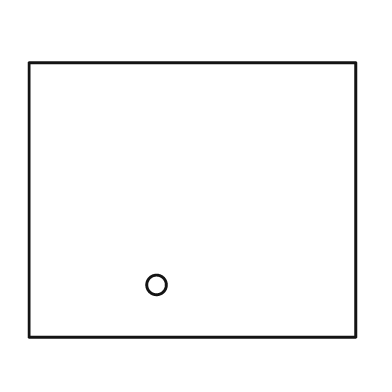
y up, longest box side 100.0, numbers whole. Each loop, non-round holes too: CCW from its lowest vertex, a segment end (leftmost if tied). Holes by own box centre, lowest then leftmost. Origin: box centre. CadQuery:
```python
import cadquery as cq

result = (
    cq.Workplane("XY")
    .moveTo(-50.0, -42.0)
    .lineTo(50.0, -42.0)
    .lineTo(50.0, 42.0)
    .lineTo(-50.0, 42.0)
    .close()
    .moveTo(-11.0, -26.0)
    .circle(3.0)
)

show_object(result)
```